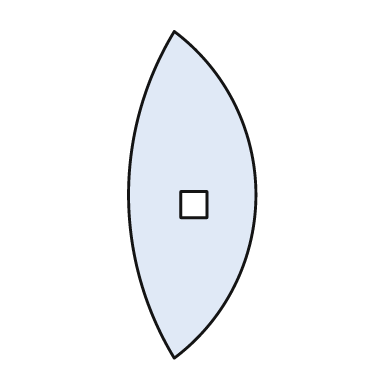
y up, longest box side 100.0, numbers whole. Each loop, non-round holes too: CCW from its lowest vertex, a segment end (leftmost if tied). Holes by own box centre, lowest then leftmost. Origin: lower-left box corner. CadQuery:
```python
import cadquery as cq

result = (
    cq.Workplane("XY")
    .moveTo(14.0, 0.0)
    .threePointArc((39.0, 50.0), (14.0, 100.0))
    .threePointArc((0.0, 50.0), (14.0, 0.0))
    .close()
    .moveTo(16.0, 43.0)
    .lineTo(24.0, 43.0)
    .lineTo(24.0, 51.0)
    .lineTo(16.0, 51.0)
    .close()
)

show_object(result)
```